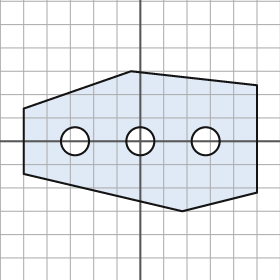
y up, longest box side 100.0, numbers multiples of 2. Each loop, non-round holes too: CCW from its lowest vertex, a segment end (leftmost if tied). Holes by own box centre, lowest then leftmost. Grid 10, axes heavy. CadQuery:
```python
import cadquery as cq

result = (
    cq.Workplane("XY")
    .moveTo(18.0, -30.0)
    .lineTo(50.0, -22.0)
    .lineTo(50.0, 24.0)
    .lineTo(-4.0, 30.0)
    .lineTo(-50.0, 14.0)
    .lineTo(-50.0, -14.0)
    .close()
    .moveTo(-28.0, 0.0)
    .circle(6.0)
    .moveTo(0.0, 0.0)
    .circle(6.0)
    .moveTo(28.0, 0.0)
    .circle(6.0)
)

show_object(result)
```